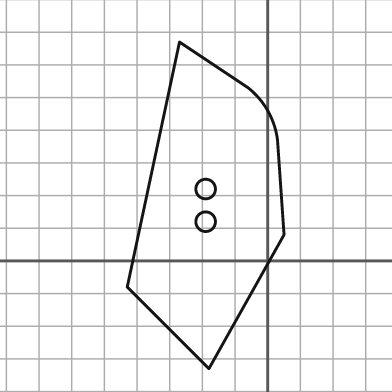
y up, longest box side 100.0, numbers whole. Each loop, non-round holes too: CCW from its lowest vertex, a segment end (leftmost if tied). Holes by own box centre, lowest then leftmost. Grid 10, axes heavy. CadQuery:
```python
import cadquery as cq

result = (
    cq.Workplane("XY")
    .moveTo(-18.0, -33.0)
    .lineTo(5.0, 8.0)
    .lineTo(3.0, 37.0)
    .threePointArc((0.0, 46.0), (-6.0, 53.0))
    .lineTo(-27.0, 67.0)
    .lineTo(-43.0, -8.0)
    .close()
    .moveTo(-19.0, 12.0)
    .circle(3.0)
    .moveTo(-19.0, 22.0)
    .circle(3.0)
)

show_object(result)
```